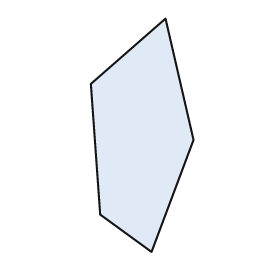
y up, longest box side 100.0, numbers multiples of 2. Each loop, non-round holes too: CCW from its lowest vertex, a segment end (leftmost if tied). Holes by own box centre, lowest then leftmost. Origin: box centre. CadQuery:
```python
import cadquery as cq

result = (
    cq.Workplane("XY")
    .moveTo(4.0, -50.0)
    .lineTo(22.0, -2.0)
    .lineTo(10.0, 50.0)
    .lineTo(-22.0, 22.0)
    .lineTo(-18.0, -34.0)
    .close()
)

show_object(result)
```